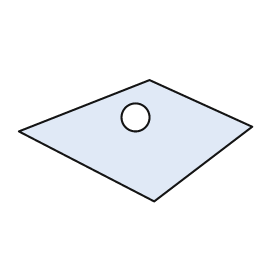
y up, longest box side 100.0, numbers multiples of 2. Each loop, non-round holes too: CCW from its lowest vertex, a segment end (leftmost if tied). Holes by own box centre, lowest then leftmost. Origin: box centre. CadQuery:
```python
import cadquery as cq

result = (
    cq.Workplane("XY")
    .moveTo(8.0, -26.0)
    .lineTo(50.0, 6.0)
    .lineTo(6.0, 26.0)
    .lineTo(-50.0, 4.0)
    .close()
    .moveTo(0.0, 10.0)
    .circle(6.0)
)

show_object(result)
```